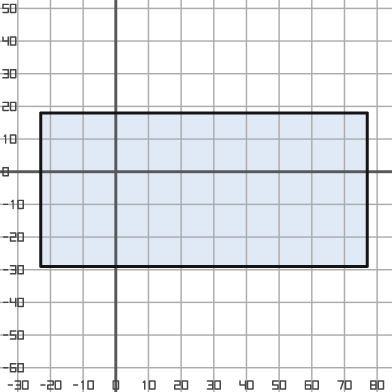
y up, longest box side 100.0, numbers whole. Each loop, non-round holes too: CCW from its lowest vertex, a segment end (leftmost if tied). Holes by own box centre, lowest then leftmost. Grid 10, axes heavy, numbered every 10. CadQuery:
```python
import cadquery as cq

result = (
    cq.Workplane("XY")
    .moveTo(-23.0, -29.0)
    .lineTo(77.0, -29.0)
    .lineTo(77.0, 18.0)
    .lineTo(-23.0, 18.0)
    .close()
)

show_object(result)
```